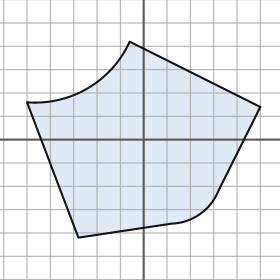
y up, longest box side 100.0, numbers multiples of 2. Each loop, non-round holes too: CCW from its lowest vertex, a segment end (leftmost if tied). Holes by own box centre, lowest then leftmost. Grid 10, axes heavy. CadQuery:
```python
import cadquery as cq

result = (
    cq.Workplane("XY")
    .moveTo(-28.0, -42.0)
    .lineTo(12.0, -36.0)
    .threePointArc((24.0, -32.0), (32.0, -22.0))
    .lineTo(50.0, 14.0)
    .lineTo(-6.0, 42.0)
    .threePointArc((-24.0, 22.0), (-50.0, 16.0))
    .close()
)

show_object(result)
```